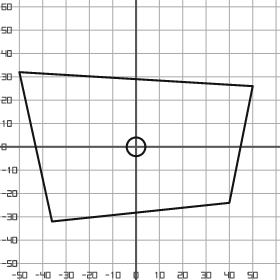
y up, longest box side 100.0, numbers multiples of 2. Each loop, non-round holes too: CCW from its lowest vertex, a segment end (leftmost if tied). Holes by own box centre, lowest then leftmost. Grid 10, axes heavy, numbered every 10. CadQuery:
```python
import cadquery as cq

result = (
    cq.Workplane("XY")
    .moveTo(-36.0, -32.0)
    .lineTo(40.0, -24.0)
    .lineTo(50.0, 26.0)
    .lineTo(-50.0, 32.0)
    .close()
    .moveTo(0.0, 0.0)
    .circle(4.0)
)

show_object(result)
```